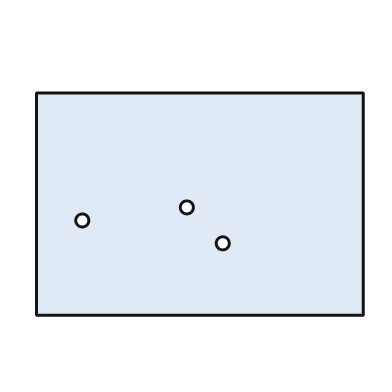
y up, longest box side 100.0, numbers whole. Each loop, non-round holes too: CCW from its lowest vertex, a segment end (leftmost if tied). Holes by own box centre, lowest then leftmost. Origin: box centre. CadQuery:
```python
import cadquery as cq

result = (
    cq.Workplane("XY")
    .moveTo(-50.0, -34.0)
    .lineTo(50.0, -34.0)
    .lineTo(50.0, 34.0)
    .lineTo(-50.0, 34.0)
    .close()
    .moveTo(7.0, -12.0)
    .circle(2.0)
    .moveTo(-36.0, -5.0)
    .circle(2.0)
    .moveTo(-4.0, -1.0)
    .circle(2.0)
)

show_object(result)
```